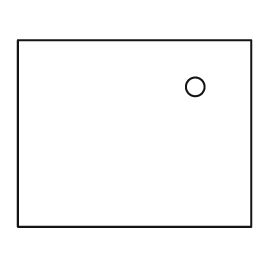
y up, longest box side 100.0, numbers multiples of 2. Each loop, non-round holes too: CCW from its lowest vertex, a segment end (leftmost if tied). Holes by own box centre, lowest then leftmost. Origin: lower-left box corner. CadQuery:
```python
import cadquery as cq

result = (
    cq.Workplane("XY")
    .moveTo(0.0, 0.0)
    .lineTo(100.0, 0.0)
    .lineTo(100.0, 80.0)
    .lineTo(0.0, 80.0)
    .close()
    .moveTo(76.0, 60.0)
    .circle(4.0)
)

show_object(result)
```